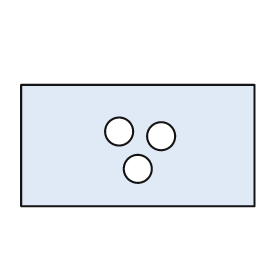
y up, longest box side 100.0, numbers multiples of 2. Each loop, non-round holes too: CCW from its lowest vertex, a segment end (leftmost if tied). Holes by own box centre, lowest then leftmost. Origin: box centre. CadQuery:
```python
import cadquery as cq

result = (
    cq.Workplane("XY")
    .moveTo(-50.0, -26.0)
    .lineTo(50.0, -26.0)
    .lineTo(50.0, 26.0)
    .lineTo(-50.0, 26.0)
    .close()
    .moveTo(0.0, -10.0)
    .circle(6.0)
    .moveTo(10.0, 4.0)
    .circle(6.0)
    .moveTo(-8.0, 6.0)
    .circle(6.0)
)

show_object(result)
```